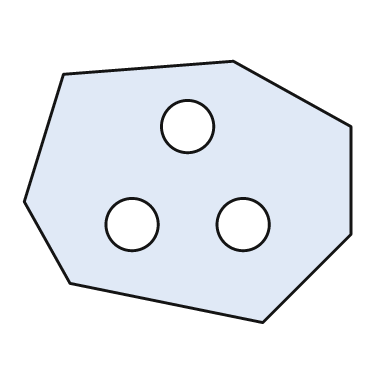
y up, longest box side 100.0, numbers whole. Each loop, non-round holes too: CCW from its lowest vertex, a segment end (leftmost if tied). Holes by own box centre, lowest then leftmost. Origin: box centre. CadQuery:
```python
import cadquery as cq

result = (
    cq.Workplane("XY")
    .moveTo(23.0, -40.0)
    .lineTo(50.0, -13.0)
    .lineTo(50.0, 20.0)
    .lineTo(14.0, 40.0)
    .lineTo(-38.0, 36.0)
    .lineTo(-50.0, -3.0)
    .lineTo(-36.0, -28.0)
    .close()
    .moveTo(-17.0, -10.0)
    .circle(8.0)
    .moveTo(17.0, -10.0)
    .circle(8.0)
    .moveTo(0.0, 20.0)
    .circle(8.0)
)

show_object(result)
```